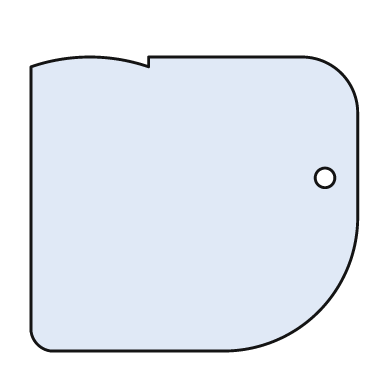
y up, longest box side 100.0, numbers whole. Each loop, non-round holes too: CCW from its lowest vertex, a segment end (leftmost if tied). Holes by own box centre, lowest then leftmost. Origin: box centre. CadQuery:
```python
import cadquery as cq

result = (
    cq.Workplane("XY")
    .moveTo(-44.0, -45.0)
    .lineTo(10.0, -45.0)
    .threePointArc((38.0, -33.0), (50.0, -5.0))
    .lineTo(50.0, 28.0)
    .threePointArc((45.0, 40.0), (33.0, 45.0))
    .lineTo(-14.0, 45.0)
    .lineTo(-14.0, 42.0)
    .threePointArc((-32.0, 45.0), (-50.0, 42.0))
    .lineTo(-50.0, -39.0)
    .threePointArc((-48.0, -43.0), (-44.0, -45.0))
    .close()
    .moveTo(40.0, 8.0)
    .circle(3.0)
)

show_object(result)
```